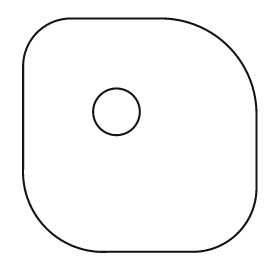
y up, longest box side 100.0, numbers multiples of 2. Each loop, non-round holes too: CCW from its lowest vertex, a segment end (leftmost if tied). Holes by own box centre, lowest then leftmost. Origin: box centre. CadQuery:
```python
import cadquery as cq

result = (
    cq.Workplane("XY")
    .moveTo(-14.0, -50.0)
    .lineTo(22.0, -50.0)
    .threePointArc((42.0, -42.0), (50.0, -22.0))
    .lineTo(50.0, 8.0)
    .threePointArc((38.0, 38.0), (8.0, 50.0))
    .lineTo(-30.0, 50.0)
    .threePointArc((-44.0, 44.0), (-50.0, 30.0))
    .lineTo(-50.0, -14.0)
    .threePointArc((-40.0, -40.0), (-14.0, -50.0))
    .close()
    .moveTo(-10.0, 10.0)
    .circle(10.0)
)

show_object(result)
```